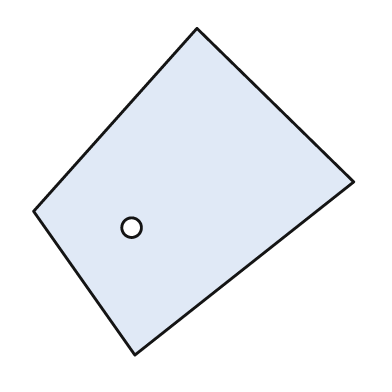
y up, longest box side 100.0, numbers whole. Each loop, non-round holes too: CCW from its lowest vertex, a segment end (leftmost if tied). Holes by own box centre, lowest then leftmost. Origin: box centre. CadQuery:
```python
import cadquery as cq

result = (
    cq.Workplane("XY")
    .moveTo(-18.0, -50.0)
    .lineTo(49.0, 3.0)
    .lineTo(1.0, 50.0)
    .lineTo(-49.0, -6.0)
    .close()
    .moveTo(-19.0, -11.0)
    .circle(3.0)
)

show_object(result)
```